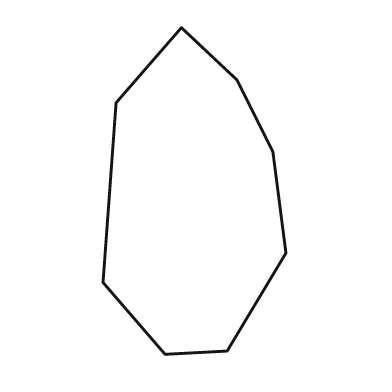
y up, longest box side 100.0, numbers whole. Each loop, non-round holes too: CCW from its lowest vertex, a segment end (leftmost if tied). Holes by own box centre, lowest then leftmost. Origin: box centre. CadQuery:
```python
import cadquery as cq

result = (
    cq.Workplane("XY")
    .moveTo(-9.0, -50.0)
    .lineTo(10.0, -49.0)
    .lineTo(28.0, -19.0)
    .lineTo(24.0, 12.0)
    .lineTo(13.0, 34.0)
    .lineTo(-4.0, 50.0)
    .lineTo(-24.0, 27.0)
    .lineTo(-28.0, -28.0)
    .close()
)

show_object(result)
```